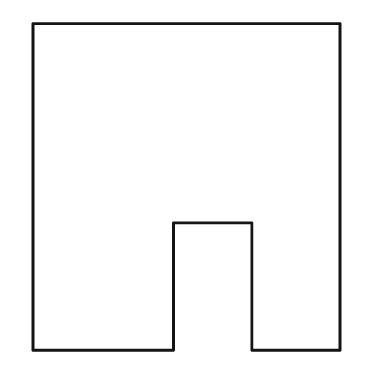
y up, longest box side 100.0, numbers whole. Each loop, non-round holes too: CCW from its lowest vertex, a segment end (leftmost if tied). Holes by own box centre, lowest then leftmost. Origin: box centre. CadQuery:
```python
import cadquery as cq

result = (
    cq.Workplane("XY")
    .moveTo(-47.0, -50.0)
    .lineTo(-4.0, -50.0)
    .lineTo(-4.0, -11.0)
    .lineTo(20.0, -11.0)
    .lineTo(20.0, -50.0)
    .lineTo(47.0, -50.0)
    .lineTo(47.0, 50.0)
    .lineTo(-47.0, 50.0)
    .close()
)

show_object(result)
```